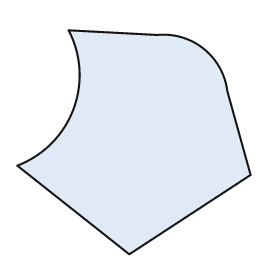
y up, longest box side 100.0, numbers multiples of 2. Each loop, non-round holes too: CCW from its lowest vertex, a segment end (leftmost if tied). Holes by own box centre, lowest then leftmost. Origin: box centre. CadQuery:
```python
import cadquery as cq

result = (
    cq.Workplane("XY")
    .moveTo(-2.0, -48.0)
    .lineTo(50.0, -14.0)
    .lineTo(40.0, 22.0)
    .threePointArc((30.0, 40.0), (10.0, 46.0))
    .lineTo(-28.0, 48.0)
    .threePointArc((-26.0, 14.0), (-50.0, -10.0))
    .close()
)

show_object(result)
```